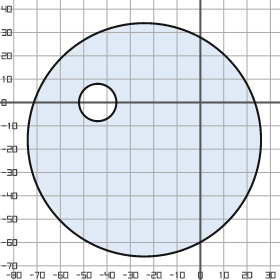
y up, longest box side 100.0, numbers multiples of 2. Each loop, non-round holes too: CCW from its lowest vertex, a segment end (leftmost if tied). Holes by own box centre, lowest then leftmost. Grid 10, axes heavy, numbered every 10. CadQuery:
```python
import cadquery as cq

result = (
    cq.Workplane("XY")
    .moveTo(-24.0, -16.0)
    .circle(50.0)
    .moveTo(-44.0, 0.0)
    .circle(8.0)
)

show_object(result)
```